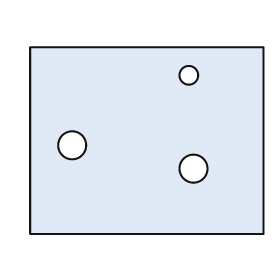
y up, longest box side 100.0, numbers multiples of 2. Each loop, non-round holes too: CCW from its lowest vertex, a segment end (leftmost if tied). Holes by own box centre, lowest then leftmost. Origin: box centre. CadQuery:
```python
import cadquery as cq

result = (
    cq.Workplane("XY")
    .moveTo(-50.0, -40.0)
    .lineTo(50.0, -40.0)
    .lineTo(50.0, 40.0)
    .lineTo(-50.0, 40.0)
    .close()
    .moveTo(20.0, -12.0)
    .circle(6.0)
    .moveTo(-32.0, -2.0)
    .circle(6.0)
    .moveTo(18.0, 28.0)
    .circle(4.0)
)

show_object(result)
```